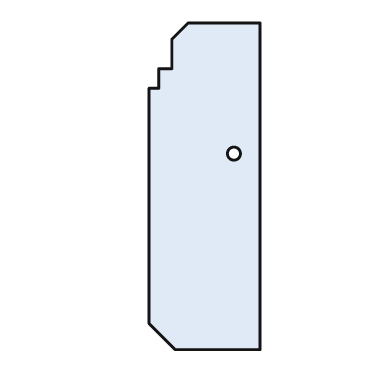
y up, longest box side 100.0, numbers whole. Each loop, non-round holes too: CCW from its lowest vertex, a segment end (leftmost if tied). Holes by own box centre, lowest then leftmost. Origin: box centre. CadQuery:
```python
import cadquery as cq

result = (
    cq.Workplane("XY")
    .moveTo(-9.0, -50.0)
    .lineTo(17.0, -50.0)
    .lineTo(17.0, 50.0)
    .lineTo(-5.0, 50.0)
    .lineTo(-10.0, 45.0)
    .lineTo(-10.0, 36.0)
    .lineTo(-14.0, 36.0)
    .lineTo(-14.0, 30.0)
    .lineTo(-17.0, 30.0)
    .lineTo(-17.0, -42.0)
    .close()
    .moveTo(9.0, 10.0)
    .circle(2.0)
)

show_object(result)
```